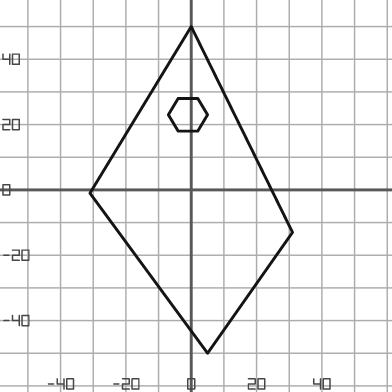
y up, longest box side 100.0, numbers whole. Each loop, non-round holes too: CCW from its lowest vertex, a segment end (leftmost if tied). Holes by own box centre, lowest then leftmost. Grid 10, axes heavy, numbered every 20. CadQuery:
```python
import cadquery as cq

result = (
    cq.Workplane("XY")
    .moveTo(5.0, -50.0)
    .lineTo(31.0, -13.0)
    .lineTo(0.0, 50.0)
    .lineTo(-31.0, -1.0)
    .close()
    .moveTo(-4.0, 18.0)
    .lineTo(2.0, 18.0)
    .lineTo(5.0, 23.0)
    .lineTo(2.0, 28.0)
    .lineTo(-4.0, 28.0)
    .lineTo(-7.0, 23.0)
    .close()
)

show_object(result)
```